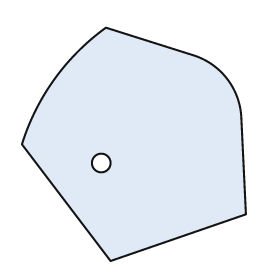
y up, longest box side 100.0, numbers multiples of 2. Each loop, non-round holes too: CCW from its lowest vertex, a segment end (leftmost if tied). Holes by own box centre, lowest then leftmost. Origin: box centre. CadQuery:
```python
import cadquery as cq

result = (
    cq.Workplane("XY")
    .moveTo(-10.0, -50.0)
    .lineTo(48.0, -30.0)
    .lineTo(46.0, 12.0)
    .threePointArc((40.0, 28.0), (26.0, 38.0))
    .lineTo(-12.0, 50.0)
    .threePointArc((-34.0, 28.0), (-48.0, 0.0))
    .close()
    .moveTo(-14.0, -8.0)
    .circle(4.0)
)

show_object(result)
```